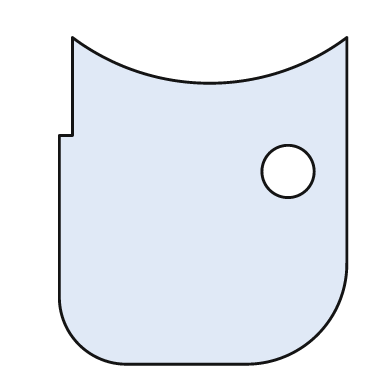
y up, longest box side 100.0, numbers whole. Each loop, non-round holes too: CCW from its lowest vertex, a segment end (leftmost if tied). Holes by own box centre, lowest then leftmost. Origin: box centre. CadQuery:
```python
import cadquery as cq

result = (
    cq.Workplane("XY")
    .moveTo(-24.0, -50.0)
    .lineTo(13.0, -50.0)
    .threePointArc((35.0, -41.0), (44.0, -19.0))
    .lineTo(44.0, 50.0)
    .threePointArc((2.0, 36.0), (-40.0, 50.0))
    .lineTo(-40.0, 20.0)
    .lineTo(-44.0, 20.0)
    .lineTo(-44.0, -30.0)
    .threePointArc((-38.0, -44.0), (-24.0, -50.0))
    .close()
    .moveTo(26.0, 9.0)
    .circle(8.0)
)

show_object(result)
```